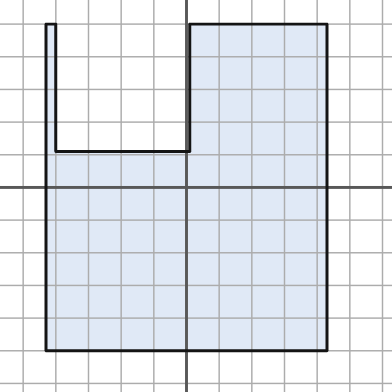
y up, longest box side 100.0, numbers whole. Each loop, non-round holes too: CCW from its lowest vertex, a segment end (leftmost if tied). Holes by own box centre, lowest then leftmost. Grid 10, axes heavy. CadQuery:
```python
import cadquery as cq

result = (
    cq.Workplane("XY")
    .moveTo(-43.0, -50.0)
    .lineTo(43.0, -50.0)
    .lineTo(43.0, 50.0)
    .lineTo(1.0, 50.0)
    .lineTo(1.0, 11.0)
    .lineTo(-40.0, 11.0)
    .lineTo(-40.0, 50.0)
    .lineTo(-43.0, 50.0)
    .close()
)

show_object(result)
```